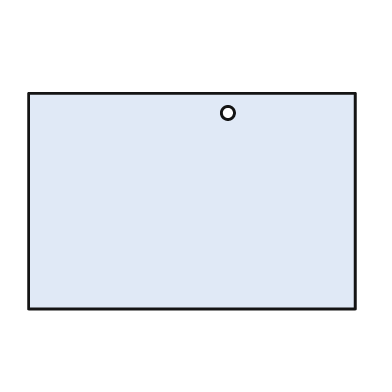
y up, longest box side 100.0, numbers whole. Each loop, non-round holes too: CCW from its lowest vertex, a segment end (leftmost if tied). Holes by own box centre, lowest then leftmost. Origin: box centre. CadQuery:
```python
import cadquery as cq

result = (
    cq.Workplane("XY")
    .moveTo(-50.0, -33.0)
    .lineTo(50.0, -33.0)
    .lineTo(50.0, 33.0)
    .lineTo(-50.0, 33.0)
    .close()
    .moveTo(11.0, 27.0)
    .circle(2.0)
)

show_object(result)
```